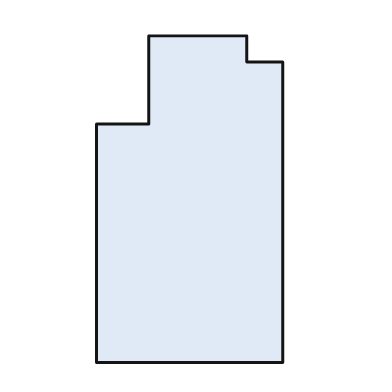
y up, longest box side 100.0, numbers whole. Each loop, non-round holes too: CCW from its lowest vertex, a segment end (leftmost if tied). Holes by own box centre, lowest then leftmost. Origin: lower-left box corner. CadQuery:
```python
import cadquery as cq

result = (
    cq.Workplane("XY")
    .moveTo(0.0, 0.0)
    .lineTo(57.0, 0.0)
    .lineTo(57.0, 92.0)
    .lineTo(46.0, 92.0)
    .lineTo(46.0, 100.0)
    .lineTo(16.0, 100.0)
    .lineTo(16.0, 73.0)
    .lineTo(0.0, 73.0)
    .close()
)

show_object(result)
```